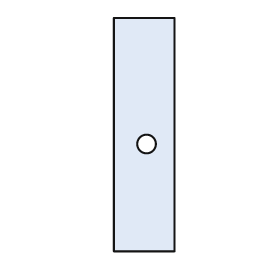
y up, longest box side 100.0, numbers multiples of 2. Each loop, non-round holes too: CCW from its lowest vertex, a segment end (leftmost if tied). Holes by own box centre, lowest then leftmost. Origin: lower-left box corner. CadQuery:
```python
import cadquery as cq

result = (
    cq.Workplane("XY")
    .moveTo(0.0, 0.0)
    .lineTo(26.0, 0.0)
    .lineTo(26.0, 100.0)
    .lineTo(0.0, 100.0)
    .close()
    .moveTo(14.0, 46.0)
    .circle(4.0)
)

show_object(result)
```